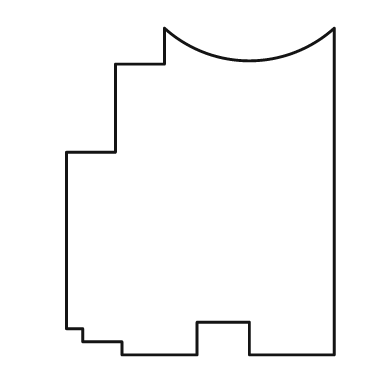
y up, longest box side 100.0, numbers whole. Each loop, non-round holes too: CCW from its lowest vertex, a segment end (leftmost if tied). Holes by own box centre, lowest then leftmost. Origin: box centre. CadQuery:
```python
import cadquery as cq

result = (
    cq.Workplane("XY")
    .moveTo(-24.0, -50.0)
    .lineTo(-1.0, -50.0)
    .lineTo(-1.0, -40.0)
    .lineTo(15.0, -40.0)
    .lineTo(15.0, -50.0)
    .lineTo(41.0, -50.0)
    .lineTo(41.0, 50.0)
    .threePointArc((15.0, 40.0), (-11.0, 50.0))
    .lineTo(-11.0, 39.0)
    .lineTo(-26.0, 39.0)
    .lineTo(-26.0, 12.0)
    .lineTo(-41.0, 12.0)
    .lineTo(-41.0, -42.0)
    .lineTo(-36.0, -42.0)
    .lineTo(-36.0, -46.0)
    .lineTo(-24.0, -46.0)
    .close()
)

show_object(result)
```